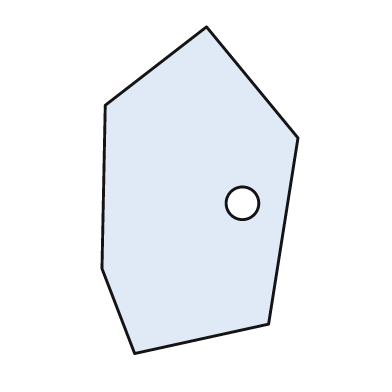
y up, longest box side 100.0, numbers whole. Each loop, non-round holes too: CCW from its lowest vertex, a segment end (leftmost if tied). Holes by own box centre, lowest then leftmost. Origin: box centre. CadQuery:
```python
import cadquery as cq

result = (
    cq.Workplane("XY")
    .moveTo(-20.0, -50.0)
    .lineTo(21.0, -41.0)
    .lineTo(30.0, 16.0)
    .lineTo(2.0, 50.0)
    .lineTo(-29.0, 26.0)
    .lineTo(-30.0, -24.0)
    .close()
    .moveTo(13.0, -4.0)
    .circle(5.0)
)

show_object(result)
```